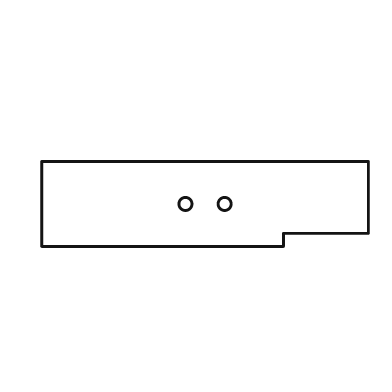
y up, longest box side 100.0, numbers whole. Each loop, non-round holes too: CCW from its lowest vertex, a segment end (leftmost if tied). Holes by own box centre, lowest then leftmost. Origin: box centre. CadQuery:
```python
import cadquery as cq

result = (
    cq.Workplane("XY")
    .moveTo(-50.0, -13.0)
    .lineTo(24.0, -13.0)
    .lineTo(24.0, -9.0)
    .lineTo(50.0, -9.0)
    .lineTo(50.0, 13.0)
    .lineTo(-50.0, 13.0)
    .close()
    .moveTo(-6.0, 0.0)
    .circle(2.0)
    .moveTo(6.0, 0.0)
    .circle(2.0)
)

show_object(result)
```